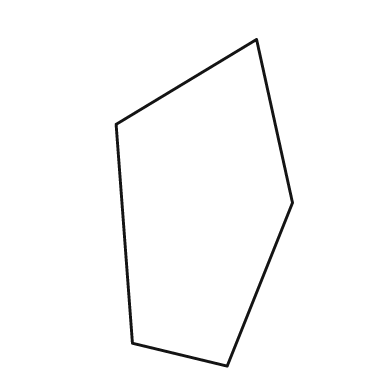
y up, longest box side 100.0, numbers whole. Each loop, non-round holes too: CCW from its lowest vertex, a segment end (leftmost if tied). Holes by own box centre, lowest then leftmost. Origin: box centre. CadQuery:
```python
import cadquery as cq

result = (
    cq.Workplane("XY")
    .moveTo(7.0, -50.0)
    .lineTo(27.0, 0.0)
    .lineTo(16.0, 50.0)
    .lineTo(-27.0, 24.0)
    .lineTo(-22.0, -43.0)
    .close()
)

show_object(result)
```